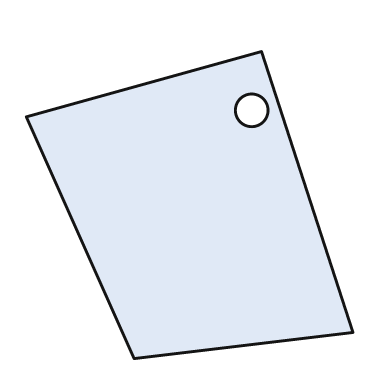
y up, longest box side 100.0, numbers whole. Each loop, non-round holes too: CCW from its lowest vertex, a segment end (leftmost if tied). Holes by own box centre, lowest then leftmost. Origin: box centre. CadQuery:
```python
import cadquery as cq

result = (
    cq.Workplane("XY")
    .moveTo(-17.0, -47.0)
    .lineTo(50.0, -39.0)
    .lineTo(22.0, 47.0)
    .lineTo(-50.0, 27.0)
    .close()
    .moveTo(19.0, 29.0)
    .circle(5.0)
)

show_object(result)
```